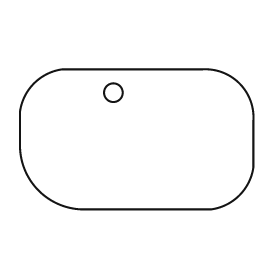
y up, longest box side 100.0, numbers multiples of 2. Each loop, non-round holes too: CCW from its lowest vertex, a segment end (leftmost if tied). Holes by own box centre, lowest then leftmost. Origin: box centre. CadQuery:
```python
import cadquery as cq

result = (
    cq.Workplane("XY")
    .moveTo(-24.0, -30.0)
    .lineTo(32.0, -30.0)
    .threePointArc((44.0, -24.0), (50.0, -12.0))
    .lineTo(50.0, 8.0)
    .threePointArc((44.0, 24.0), (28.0, 30.0))
    .lineTo(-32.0, 30.0)
    .threePointArc((-44.0, 24.0), (-50.0, 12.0))
    .lineTo(-50.0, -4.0)
    .threePointArc((-42.0, -22.0), (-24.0, -30.0))
    .close()
    .moveTo(-10.0, 20.0)
    .circle(4.0)
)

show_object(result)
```